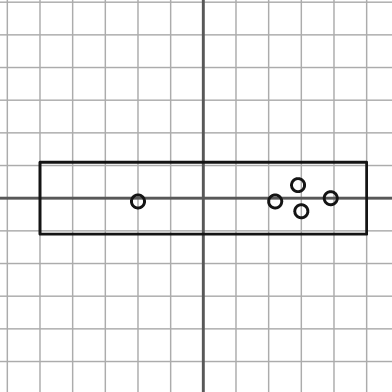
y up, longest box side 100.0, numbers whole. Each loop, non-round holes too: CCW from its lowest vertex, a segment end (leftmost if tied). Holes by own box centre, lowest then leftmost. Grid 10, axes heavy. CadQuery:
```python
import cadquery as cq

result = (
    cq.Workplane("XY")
    .moveTo(-50.0, -11.0)
    .lineTo(50.0, -11.0)
    .lineTo(50.0, 11.0)
    .lineTo(-50.0, 11.0)
    .close()
    .moveTo(30.0, -4.0)
    .circle(2.0)
    .moveTo(-20.0, -1.0)
    .circle(2.0)
    .moveTo(22.0, -1.0)
    .circle(2.0)
    .moveTo(39.0, 0.0)
    .circle(2.0)
    .moveTo(29.0, 4.0)
    .circle(2.0)
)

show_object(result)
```